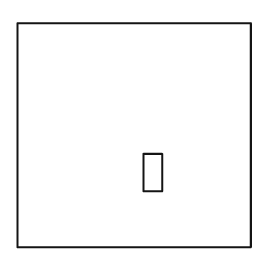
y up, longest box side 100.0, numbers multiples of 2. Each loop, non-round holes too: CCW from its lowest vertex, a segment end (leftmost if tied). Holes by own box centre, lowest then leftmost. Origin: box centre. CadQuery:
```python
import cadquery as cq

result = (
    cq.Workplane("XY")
    .moveTo(-50.0, -48.0)
    .lineTo(50.0, -48.0)
    .lineTo(50.0, 48.0)
    .lineTo(-50.0, 48.0)
    .close()
    .moveTo(4.0, -24.0)
    .lineTo(12.0, -24.0)
    .lineTo(12.0, -8.0)
    .lineTo(4.0, -8.0)
    .close()
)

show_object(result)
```